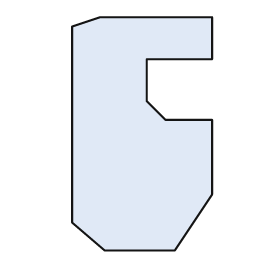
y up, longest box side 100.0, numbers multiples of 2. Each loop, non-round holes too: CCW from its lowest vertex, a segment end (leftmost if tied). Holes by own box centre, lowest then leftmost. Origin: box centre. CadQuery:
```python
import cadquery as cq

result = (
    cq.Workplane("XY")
    .moveTo(-16.0, -50.0)
    .lineTo(14.0, -50.0)
    .lineTo(30.0, -26.0)
    .lineTo(30.0, 6.0)
    .lineTo(10.0, 6.0)
    .lineTo(2.0, 14.0)
    .lineTo(2.0, 32.0)
    .lineTo(30.0, 32.0)
    .lineTo(30.0, 50.0)
    .lineTo(-18.0, 50.0)
    .lineTo(-30.0, 46.0)
    .lineTo(-30.0, -38.0)
    .close()
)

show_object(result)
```